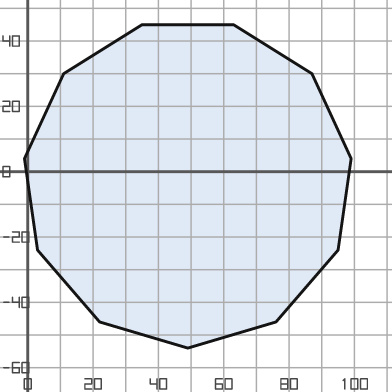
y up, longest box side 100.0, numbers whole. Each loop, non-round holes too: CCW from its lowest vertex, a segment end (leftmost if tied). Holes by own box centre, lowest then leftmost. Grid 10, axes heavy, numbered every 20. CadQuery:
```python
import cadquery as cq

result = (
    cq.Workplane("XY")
    .moveTo(49.0, -54.0)
    .lineTo(76.0, -46.0)
    .lineTo(95.0, -24.0)
    .lineTo(99.0, 4.0)
    .lineTo(87.0, 30.0)
    .lineTo(63.0, 45.0)
    .lineTo(35.0, 45.0)
    .lineTo(11.0, 30.0)
    .lineTo(-1.0, 4.0)
    .lineTo(3.0, -24.0)
    .lineTo(22.0, -46.0)
    .close()
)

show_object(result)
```